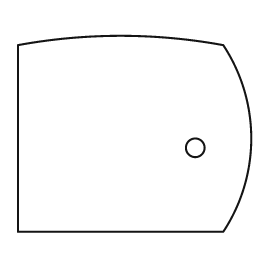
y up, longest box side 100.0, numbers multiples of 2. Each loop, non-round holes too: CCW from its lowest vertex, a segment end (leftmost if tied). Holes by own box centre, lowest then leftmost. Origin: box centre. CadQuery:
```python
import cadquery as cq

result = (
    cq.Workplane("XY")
    .moveTo(-50.0, -42.0)
    .lineTo(38.0, -42.0)
    .threePointArc((50.0, -2.0), (38.0, 38.0))
    .threePointArc((-6.0, 42.0), (-50.0, 38.0))
    .close()
    .moveTo(26.0, -6.0)
    .circle(4.0)
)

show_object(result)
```